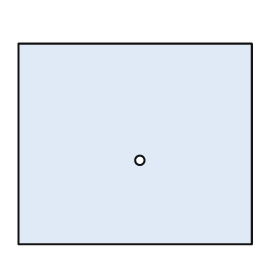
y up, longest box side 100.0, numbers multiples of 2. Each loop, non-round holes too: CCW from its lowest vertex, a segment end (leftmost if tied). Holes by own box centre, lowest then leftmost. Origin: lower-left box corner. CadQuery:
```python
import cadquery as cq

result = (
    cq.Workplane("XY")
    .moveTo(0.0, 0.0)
    .lineTo(100.0, 0.0)
    .lineTo(100.0, 86.0)
    .lineTo(0.0, 86.0)
    .close()
    .moveTo(52.0, 36.0)
    .circle(2.0)
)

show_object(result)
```